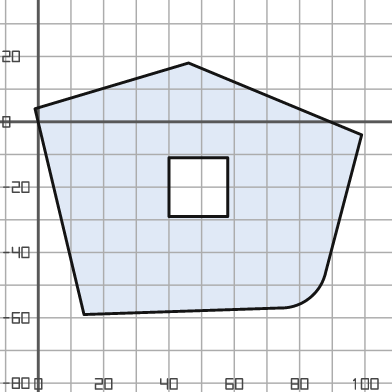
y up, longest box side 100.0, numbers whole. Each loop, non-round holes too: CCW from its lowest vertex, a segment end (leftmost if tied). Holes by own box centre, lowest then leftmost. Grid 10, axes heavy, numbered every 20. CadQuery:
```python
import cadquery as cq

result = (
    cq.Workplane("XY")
    .moveTo(14.0, -59.0)
    .lineTo(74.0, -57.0)
    .threePointArc((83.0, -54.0), (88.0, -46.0))
    .lineTo(99.0, -4.0)
    .lineTo(46.0, 18.0)
    .lineTo(-1.0, 4.0)
    .close()
    .moveTo(40.0, -29.0)
    .lineTo(58.0, -29.0)
    .lineTo(58.0, -11.0)
    .lineTo(40.0, -11.0)
    .close()
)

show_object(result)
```